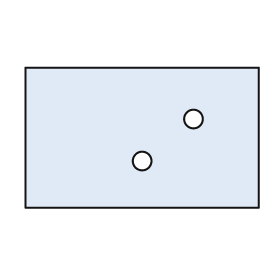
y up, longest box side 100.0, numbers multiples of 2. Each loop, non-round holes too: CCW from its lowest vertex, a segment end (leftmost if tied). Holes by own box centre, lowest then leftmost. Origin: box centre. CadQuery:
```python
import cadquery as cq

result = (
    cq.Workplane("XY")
    .moveTo(-50.0, -30.0)
    .lineTo(50.0, -30.0)
    .lineTo(50.0, 30.0)
    .lineTo(-50.0, 30.0)
    .close()
    .moveTo(0.0, -10.0)
    .circle(4.0)
    .moveTo(22.0, 8.0)
    .circle(4.0)
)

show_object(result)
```